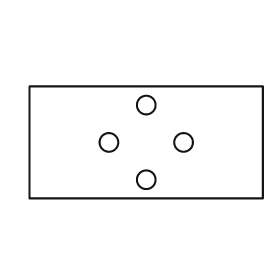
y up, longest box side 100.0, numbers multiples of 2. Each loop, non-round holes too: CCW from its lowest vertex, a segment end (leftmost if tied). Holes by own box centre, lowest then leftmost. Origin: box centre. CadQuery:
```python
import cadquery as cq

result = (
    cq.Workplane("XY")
    .moveTo(-50.0, -24.0)
    .lineTo(50.0, -24.0)
    .lineTo(50.0, 24.0)
    .lineTo(-50.0, 24.0)
    .close()
    .moveTo(0.0, -16.0)
    .circle(4.0)
    .moveTo(-16.0, 0.0)
    .circle(4.0)
    .moveTo(16.0, 0.0)
    .circle(4.0)
    .moveTo(0.0, 16.0)
    .circle(4.0)
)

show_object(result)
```